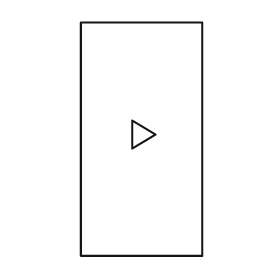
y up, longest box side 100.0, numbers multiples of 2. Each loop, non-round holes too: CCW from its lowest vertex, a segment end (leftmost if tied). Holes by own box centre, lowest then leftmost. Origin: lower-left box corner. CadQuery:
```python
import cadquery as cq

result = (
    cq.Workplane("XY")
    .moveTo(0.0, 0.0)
    .lineTo(52.0, 0.0)
    .lineTo(52.0, 100.0)
    .lineTo(0.0, 100.0)
    .close()
    .moveTo(22.0, 46.0)
    .lineTo(32.0, 52.0)
    .lineTo(22.0, 58.0)
    .close()
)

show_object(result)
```